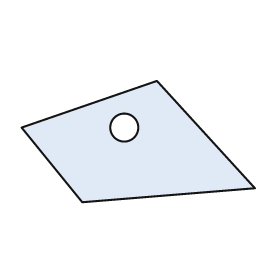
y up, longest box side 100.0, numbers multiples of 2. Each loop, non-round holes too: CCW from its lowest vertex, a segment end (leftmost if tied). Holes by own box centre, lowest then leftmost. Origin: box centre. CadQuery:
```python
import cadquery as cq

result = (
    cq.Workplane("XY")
    .moveTo(-24.0, -26.0)
    .lineTo(50.0, -20.0)
    .lineTo(8.0, 26.0)
    .lineTo(-50.0, 6.0)
    .close()
    .moveTo(-6.0, 6.0)
    .circle(6.0)
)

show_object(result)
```